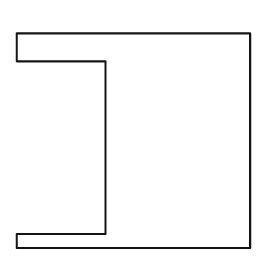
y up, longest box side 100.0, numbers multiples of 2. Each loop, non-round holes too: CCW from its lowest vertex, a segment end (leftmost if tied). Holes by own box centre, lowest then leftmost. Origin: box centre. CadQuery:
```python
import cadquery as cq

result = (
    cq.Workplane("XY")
    .moveTo(-50.0, -46.0)
    .lineTo(50.0, -46.0)
    .lineTo(50.0, 46.0)
    .lineTo(-50.0, 46.0)
    .lineTo(-50.0, 34.0)
    .lineTo(-12.0, 34.0)
    .lineTo(-12.0, -40.0)
    .lineTo(-50.0, -40.0)
    .close()
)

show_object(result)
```